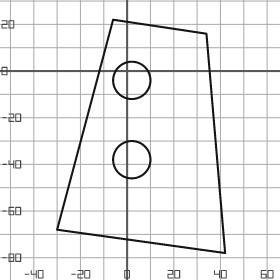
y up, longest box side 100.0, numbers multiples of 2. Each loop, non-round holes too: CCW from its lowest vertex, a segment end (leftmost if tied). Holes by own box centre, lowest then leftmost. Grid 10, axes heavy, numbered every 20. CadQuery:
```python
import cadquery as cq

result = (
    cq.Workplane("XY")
    .moveTo(42.0, -78.0)
    .lineTo(34.0, 16.0)
    .lineTo(-6.0, 22.0)
    .lineTo(-30.0, -68.0)
    .close()
    .moveTo(2.0, -38.0)
    .circle(8.0)
    .moveTo(2.0, -4.0)
    .circle(8.0)
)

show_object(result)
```